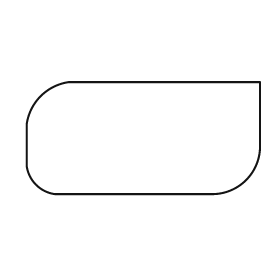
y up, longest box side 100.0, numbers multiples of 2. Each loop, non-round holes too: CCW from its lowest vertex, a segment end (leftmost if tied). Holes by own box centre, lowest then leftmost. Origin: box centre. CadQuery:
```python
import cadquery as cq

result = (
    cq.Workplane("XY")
    .moveTo(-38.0, -24.0)
    .lineTo(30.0, -24.0)
    .threePointArc((44.0, -18.0), (50.0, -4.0))
    .lineTo(50.0, 24.0)
    .lineTo(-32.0, 24.0)
    .threePointArc((-44.0, 18.0), (-50.0, 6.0))
    .lineTo(-50.0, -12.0)
    .threePointArc((-46.0, -20.0), (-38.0, -24.0))
    .close()
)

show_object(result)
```